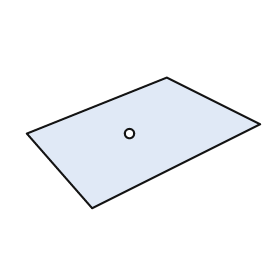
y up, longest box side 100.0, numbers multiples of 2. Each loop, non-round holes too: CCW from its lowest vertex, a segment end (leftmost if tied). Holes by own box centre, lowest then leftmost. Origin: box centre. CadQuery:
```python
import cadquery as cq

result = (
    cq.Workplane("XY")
    .moveTo(-22.0, -28.0)
    .lineTo(50.0, 8.0)
    .lineTo(10.0, 28.0)
    .lineTo(-50.0, 4.0)
    .close()
    .moveTo(-6.0, 4.0)
    .circle(2.0)
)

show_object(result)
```